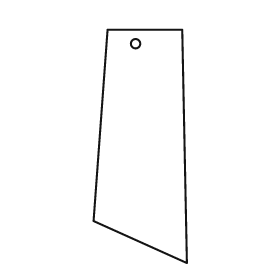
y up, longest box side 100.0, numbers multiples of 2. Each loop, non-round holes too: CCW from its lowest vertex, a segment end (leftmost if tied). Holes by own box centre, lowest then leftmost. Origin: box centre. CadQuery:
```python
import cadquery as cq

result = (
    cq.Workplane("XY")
    .moveTo(20.0, -50.0)
    .lineTo(18.0, 50.0)
    .lineTo(-14.0, 50.0)
    .lineTo(-20.0, -32.0)
    .close()
    .moveTo(-2.0, 44.0)
    .circle(2.0)
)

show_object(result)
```